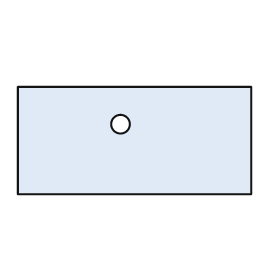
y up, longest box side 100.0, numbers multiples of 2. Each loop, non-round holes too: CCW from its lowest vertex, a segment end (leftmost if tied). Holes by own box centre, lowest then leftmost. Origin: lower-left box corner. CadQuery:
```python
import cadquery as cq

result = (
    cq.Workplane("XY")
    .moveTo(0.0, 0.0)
    .lineTo(100.0, 0.0)
    .lineTo(100.0, 46.0)
    .lineTo(0.0, 46.0)
    .close()
    .moveTo(44.0, 30.0)
    .circle(4.0)
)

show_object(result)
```